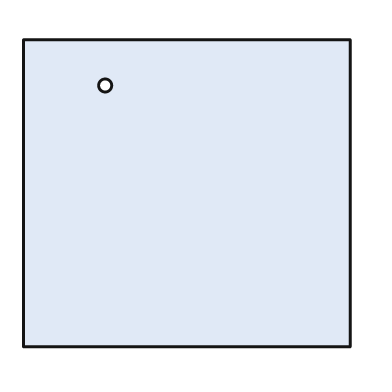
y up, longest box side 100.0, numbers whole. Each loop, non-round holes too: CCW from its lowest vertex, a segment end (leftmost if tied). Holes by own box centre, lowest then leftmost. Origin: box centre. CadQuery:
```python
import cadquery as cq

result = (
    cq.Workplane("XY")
    .moveTo(-50.0, -47.0)
    .lineTo(50.0, -47.0)
    .lineTo(50.0, 47.0)
    .lineTo(-50.0, 47.0)
    .close()
    .moveTo(-25.0, 33.0)
    .circle(2.0)
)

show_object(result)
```